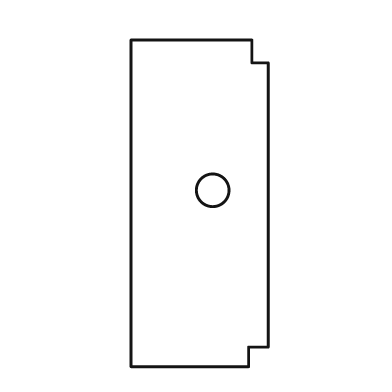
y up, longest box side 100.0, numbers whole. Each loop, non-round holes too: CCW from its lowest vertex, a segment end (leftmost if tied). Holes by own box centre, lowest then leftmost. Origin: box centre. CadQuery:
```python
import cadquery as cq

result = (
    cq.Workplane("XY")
    .moveTo(-21.0, -50.0)
    .lineTo(15.0, -50.0)
    .lineTo(15.0, -44.0)
    .lineTo(21.0, -44.0)
    .lineTo(21.0, 43.0)
    .lineTo(16.0, 43.0)
    .lineTo(16.0, 50.0)
    .lineTo(-21.0, 50.0)
    .close()
    .moveTo(4.0, 4.0)
    .circle(5.0)
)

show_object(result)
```